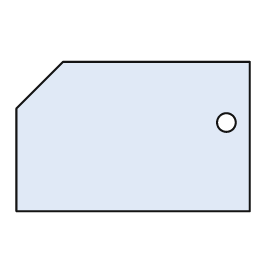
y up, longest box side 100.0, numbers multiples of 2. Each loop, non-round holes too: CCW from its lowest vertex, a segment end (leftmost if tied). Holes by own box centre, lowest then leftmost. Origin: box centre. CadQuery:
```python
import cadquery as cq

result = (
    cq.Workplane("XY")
    .moveTo(-50.0, -32.0)
    .lineTo(50.0, -32.0)
    .lineTo(50.0, 32.0)
    .lineTo(-30.0, 32.0)
    .lineTo(-50.0, 12.0)
    .close()
    .moveTo(40.0, 6.0)
    .circle(4.0)
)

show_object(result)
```